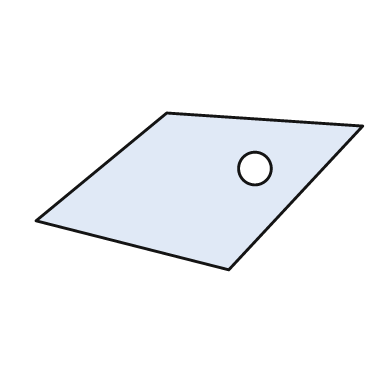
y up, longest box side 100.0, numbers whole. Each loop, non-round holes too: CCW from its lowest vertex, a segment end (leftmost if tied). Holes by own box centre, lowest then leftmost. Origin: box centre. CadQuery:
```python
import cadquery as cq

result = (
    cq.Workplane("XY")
    .moveTo(9.0, -24.0)
    .lineTo(50.0, 20.0)
    .lineTo(-10.0, 24.0)
    .lineTo(-50.0, -9.0)
    .close()
    .moveTo(17.0, 7.0)
    .circle(5.0)
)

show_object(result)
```